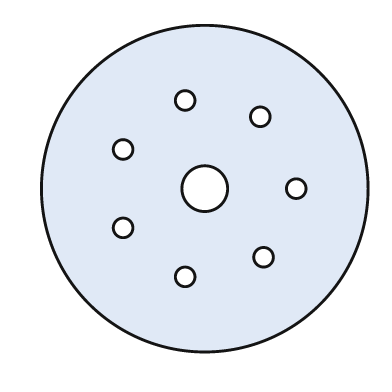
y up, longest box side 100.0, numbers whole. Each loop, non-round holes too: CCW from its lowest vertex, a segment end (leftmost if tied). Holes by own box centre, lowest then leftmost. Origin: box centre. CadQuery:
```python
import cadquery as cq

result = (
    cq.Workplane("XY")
    .moveTo(0.0, 0.0)
    .circle(50.0)
    .moveTo(-6.0, -27.0)
    .circle(3.0)
    .moveTo(18.0, -21.0)
    .circle(3.0)
    .moveTo(-25.0, -12.0)
    .circle(3.0)
    .moveTo(0.0, 0.0)
    .circle(7.0)
    .moveTo(28.0, 0.0)
    .circle(3.0)
    .moveTo(-25.0, 12.0)
    .circle(3.0)
    .moveTo(17.0, 22.0)
    .circle(3.0)
    .moveTo(-6.0, 27.0)
    .circle(3.0)
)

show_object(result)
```